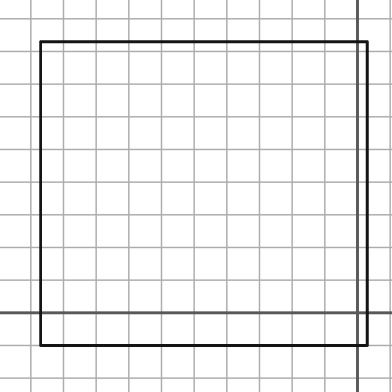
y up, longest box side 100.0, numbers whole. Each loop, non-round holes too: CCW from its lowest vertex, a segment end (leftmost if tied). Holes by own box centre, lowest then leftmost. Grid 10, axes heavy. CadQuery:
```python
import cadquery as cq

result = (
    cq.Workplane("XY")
    .moveTo(-97.0, -10.0)
    .lineTo(3.0, -10.0)
    .lineTo(3.0, 83.0)
    .lineTo(-97.0, 83.0)
    .close()
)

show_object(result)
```